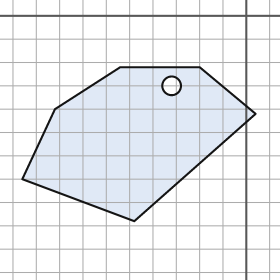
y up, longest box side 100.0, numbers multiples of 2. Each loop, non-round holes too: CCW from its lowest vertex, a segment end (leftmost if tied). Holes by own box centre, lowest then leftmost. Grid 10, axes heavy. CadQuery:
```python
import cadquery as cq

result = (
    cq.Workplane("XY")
    .moveTo(-48.0, -88.0)
    .lineTo(4.0, -42.0)
    .lineTo(-20.0, -22.0)
    .lineTo(-54.0, -22.0)
    .lineTo(-82.0, -40.0)
    .lineTo(-96.0, -70.0)
    .close()
    .moveTo(-32.0, -30.0)
    .circle(4.0)
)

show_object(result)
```